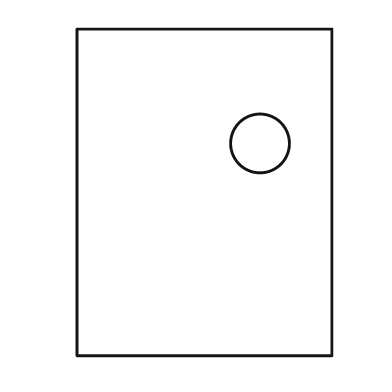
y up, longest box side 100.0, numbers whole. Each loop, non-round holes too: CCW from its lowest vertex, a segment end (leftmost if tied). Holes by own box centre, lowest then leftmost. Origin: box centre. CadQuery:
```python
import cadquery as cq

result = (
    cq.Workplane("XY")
    .moveTo(-39.0, -50.0)
    .lineTo(39.0, -50.0)
    .lineTo(39.0, 50.0)
    .lineTo(-39.0, 50.0)
    .close()
    .moveTo(17.0, 15.0)
    .circle(9.0)
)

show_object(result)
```